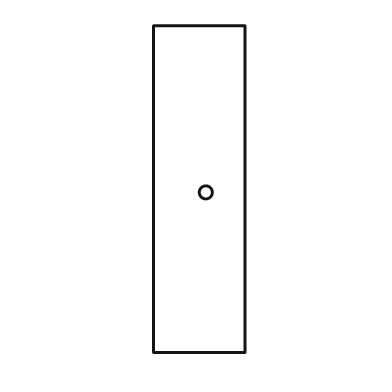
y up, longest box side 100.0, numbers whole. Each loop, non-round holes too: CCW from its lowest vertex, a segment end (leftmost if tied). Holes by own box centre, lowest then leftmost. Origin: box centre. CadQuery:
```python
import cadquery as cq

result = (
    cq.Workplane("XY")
    .moveTo(-14.0, -50.0)
    .lineTo(14.0, -50.0)
    .lineTo(14.0, 50.0)
    .lineTo(-14.0, 50.0)
    .close()
    .moveTo(2.0, -1.0)
    .circle(2.0)
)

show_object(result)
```